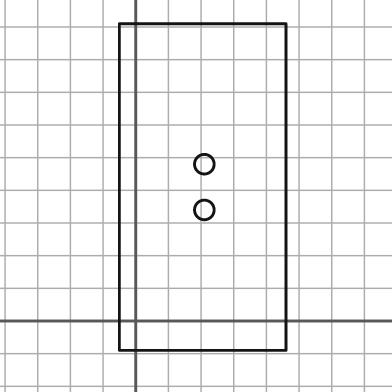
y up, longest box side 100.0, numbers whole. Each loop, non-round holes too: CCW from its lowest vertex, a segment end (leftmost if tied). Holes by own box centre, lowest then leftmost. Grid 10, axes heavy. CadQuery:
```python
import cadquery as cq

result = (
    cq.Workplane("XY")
    .moveTo(-5.0, -9.0)
    .lineTo(46.0, -9.0)
    .lineTo(46.0, 91.0)
    .lineTo(-5.0, 91.0)
    .close()
    .moveTo(21.0, 34.0)
    .circle(3.0)
    .moveTo(21.0, 48.0)
    .circle(3.0)
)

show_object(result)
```